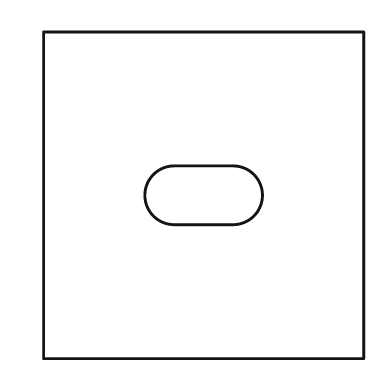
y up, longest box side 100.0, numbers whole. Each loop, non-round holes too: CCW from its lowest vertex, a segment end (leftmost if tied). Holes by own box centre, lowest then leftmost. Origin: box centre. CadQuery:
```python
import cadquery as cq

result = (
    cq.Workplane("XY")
    .moveTo(-49.0, -50.0)
    .lineTo(49.0, -50.0)
    .lineTo(49.0, 50.0)
    .lineTo(-49.0, 50.0)
    .close()
    .moveTo(-9.0, -9.0)
    .lineTo(9.0, -9.0)
    .threePointArc((18.0, 0.0), (9.0, 9.0))
    .lineTo(-9.0, 9.0)
    .threePointArc((-18.0, 0.0), (-9.0, -9.0))
    .close()
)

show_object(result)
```